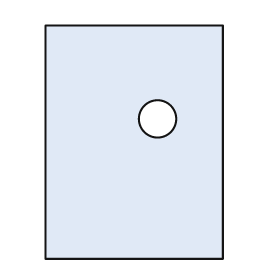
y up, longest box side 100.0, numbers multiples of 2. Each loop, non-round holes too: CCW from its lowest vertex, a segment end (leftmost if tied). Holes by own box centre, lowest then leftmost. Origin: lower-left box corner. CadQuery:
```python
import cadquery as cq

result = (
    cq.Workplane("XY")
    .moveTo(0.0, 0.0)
    .lineTo(76.0, 0.0)
    .lineTo(76.0, 100.0)
    .lineTo(0.0, 100.0)
    .close()
    .moveTo(48.0, 60.0)
    .circle(8.0)
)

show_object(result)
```